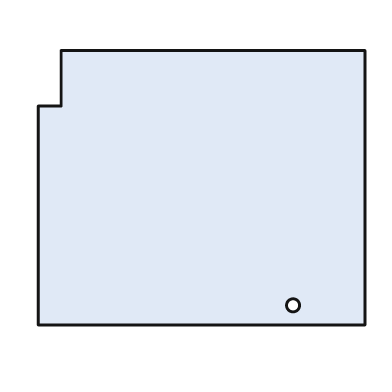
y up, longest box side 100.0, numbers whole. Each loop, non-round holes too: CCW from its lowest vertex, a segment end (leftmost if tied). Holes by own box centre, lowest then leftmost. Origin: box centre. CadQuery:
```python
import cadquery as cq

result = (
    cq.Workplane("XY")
    .moveTo(-50.0, -42.0)
    .lineTo(50.0, -42.0)
    .lineTo(50.0, 42.0)
    .lineTo(-43.0, 42.0)
    .lineTo(-43.0, 25.0)
    .lineTo(-50.0, 25.0)
    .close()
    .moveTo(28.0, -36.0)
    .circle(2.0)
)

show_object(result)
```